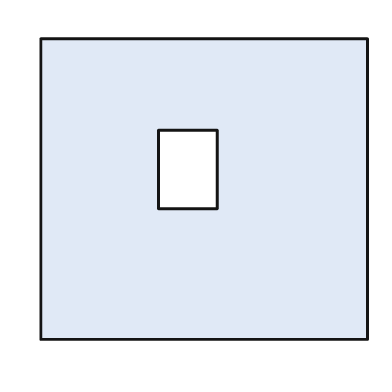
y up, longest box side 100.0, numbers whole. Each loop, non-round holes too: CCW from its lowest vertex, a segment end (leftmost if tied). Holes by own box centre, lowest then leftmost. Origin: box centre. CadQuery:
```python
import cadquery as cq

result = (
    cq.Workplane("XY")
    .moveTo(-50.0, -46.0)
    .lineTo(50.0, -46.0)
    .lineTo(50.0, 46.0)
    .lineTo(-50.0, 46.0)
    .close()
    .moveTo(-14.0, -6.0)
    .lineTo(4.0, -6.0)
    .lineTo(4.0, 18.0)
    .lineTo(-14.0, 18.0)
    .close()
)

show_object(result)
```